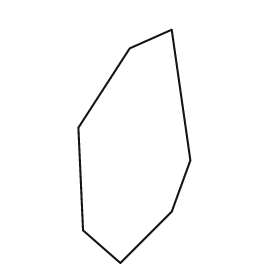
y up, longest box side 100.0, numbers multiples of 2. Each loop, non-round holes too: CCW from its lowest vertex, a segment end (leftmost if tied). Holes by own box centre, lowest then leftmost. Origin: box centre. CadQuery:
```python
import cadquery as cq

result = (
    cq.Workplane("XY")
    .moveTo(-6.0, -50.0)
    .lineTo(16.0, -28.0)
    .lineTo(24.0, -6.0)
    .lineTo(16.0, 50.0)
    .lineTo(-2.0, 42.0)
    .lineTo(-24.0, 8.0)
    .lineTo(-22.0, -36.0)
    .close()
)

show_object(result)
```